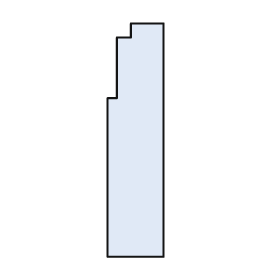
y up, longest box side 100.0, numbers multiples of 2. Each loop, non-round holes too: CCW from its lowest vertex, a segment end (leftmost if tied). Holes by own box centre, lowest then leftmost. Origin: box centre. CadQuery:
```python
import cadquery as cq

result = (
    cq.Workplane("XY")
    .moveTo(-12.0, -50.0)
    .lineTo(12.0, -50.0)
    .lineTo(12.0, 50.0)
    .lineTo(-2.0, 50.0)
    .lineTo(-2.0, 44.0)
    .lineTo(-8.0, 44.0)
    .lineTo(-8.0, 18.0)
    .lineTo(-12.0, 18.0)
    .close()
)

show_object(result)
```